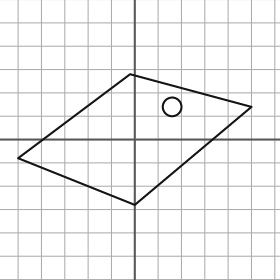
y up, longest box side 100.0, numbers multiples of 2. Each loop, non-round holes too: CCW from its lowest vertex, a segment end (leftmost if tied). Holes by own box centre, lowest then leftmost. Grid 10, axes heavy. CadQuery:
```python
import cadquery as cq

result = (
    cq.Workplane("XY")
    .moveTo(0.0, -28.0)
    .lineTo(50.0, 14.0)
    .lineTo(-2.0, 28.0)
    .lineTo(-50.0, -8.0)
    .close()
    .moveTo(16.0, 14.0)
    .circle(4.0)
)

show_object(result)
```